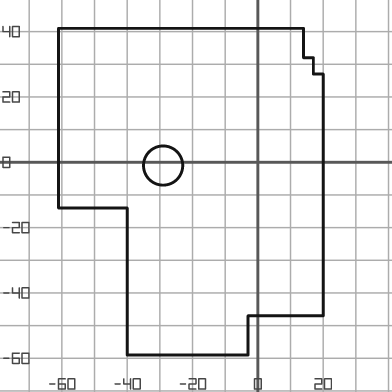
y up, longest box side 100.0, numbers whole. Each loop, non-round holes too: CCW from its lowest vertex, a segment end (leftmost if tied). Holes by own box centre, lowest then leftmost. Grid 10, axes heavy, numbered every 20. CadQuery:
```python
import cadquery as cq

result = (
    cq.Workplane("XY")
    .moveTo(-40.0, -59.0)
    .lineTo(-3.0, -59.0)
    .lineTo(-3.0, -47.0)
    .lineTo(20.0, -47.0)
    .lineTo(20.0, 27.0)
    .lineTo(17.0, 27.0)
    .lineTo(17.0, 32.0)
    .lineTo(14.0, 32.0)
    .lineTo(14.0, 41.0)
    .lineTo(-61.0, 41.0)
    .lineTo(-61.0, -14.0)
    .lineTo(-40.0, -14.0)
    .close()
    .moveTo(-29.0, -1.0)
    .circle(6.0)
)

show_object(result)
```